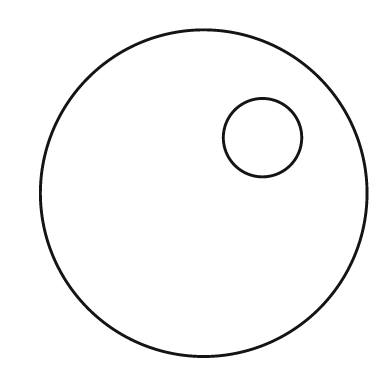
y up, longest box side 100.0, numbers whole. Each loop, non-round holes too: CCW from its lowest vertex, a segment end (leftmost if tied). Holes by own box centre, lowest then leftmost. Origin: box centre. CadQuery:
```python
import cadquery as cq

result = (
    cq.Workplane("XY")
    .moveTo(0.0, 0.0)
    .circle(50.0)
    .moveTo(18.0, 17.0)
    .circle(12.0)
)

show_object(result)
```